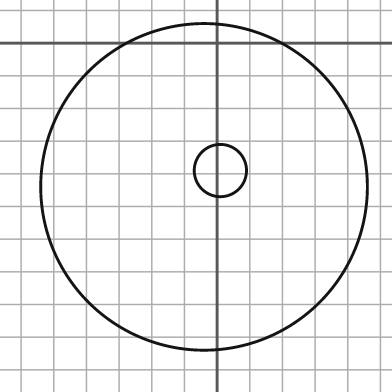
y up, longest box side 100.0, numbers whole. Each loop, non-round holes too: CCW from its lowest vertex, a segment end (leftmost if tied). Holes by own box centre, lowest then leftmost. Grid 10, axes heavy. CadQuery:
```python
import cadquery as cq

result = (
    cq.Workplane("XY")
    .moveTo(-4.0, -44.0)
    .circle(50.0)
    .moveTo(1.0, -39.0)
    .circle(8.0)
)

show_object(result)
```